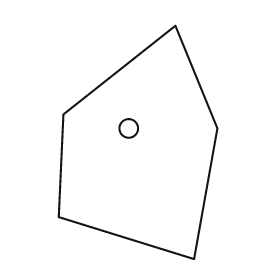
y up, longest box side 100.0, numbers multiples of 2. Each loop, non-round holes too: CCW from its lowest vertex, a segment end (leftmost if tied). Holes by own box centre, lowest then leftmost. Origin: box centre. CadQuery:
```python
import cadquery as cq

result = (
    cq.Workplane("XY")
    .moveTo(24.0, -50.0)
    .lineTo(34.0, 6.0)
    .lineTo(16.0, 50.0)
    .lineTo(-32.0, 12.0)
    .lineTo(-34.0, -32.0)
    .close()
    .moveTo(-4.0, 6.0)
    .circle(4.0)
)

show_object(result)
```